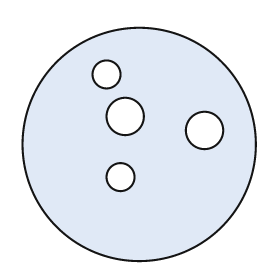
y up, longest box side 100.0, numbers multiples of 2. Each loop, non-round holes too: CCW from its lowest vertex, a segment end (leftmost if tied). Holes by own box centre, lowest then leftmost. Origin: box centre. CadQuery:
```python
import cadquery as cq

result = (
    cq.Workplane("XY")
    .moveTo(0.0, 0.0)
    .circle(50.0)
    .moveTo(-8.0, -14.0)
    .circle(6.0)
    .moveTo(28.0, 6.0)
    .circle(8.0)
    .moveTo(-6.0, 12.0)
    .circle(8.0)
    .moveTo(-14.0, 30.0)
    .circle(6.0)
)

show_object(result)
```